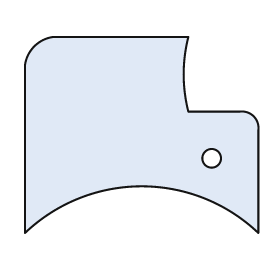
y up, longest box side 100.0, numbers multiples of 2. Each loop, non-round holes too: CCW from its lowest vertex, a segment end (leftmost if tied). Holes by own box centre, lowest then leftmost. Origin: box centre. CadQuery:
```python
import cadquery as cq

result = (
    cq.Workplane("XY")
    .moveTo(-50.0, -42.0)
    .threePointArc((0.0, -22.0), (50.0, -42.0))
    .lineTo(50.0, 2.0)
    .threePointArc((48.0, 8.0), (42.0, 10.0))
    .lineTo(20.0, 10.0)
    .threePointArc((18.0, 26.0), (20.0, 42.0))
    .lineTo(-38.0, 42.0)
    .threePointArc((-46.0, 38.0), (-50.0, 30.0))
    .close()
    .moveTo(30.0, -10.0)
    .circle(4.0)
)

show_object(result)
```